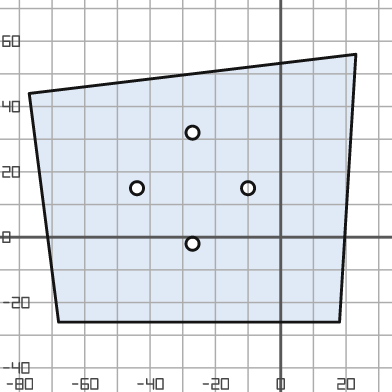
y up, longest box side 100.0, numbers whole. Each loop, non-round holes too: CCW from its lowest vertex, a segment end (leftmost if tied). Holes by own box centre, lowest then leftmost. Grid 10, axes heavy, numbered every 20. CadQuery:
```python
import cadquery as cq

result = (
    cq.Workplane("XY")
    .moveTo(-68.0, -26.0)
    .lineTo(18.0, -26.0)
    .lineTo(23.0, 56.0)
    .lineTo(-77.0, 44.0)
    .close()
    .moveTo(-27.0, -2.0)
    .circle(2.0)
    .moveTo(-44.0, 15.0)
    .circle(2.0)
    .moveTo(-10.0, 15.0)
    .circle(2.0)
    .moveTo(-27.0, 32.0)
    .circle(2.0)
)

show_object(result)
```